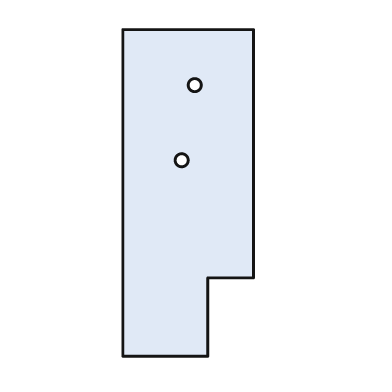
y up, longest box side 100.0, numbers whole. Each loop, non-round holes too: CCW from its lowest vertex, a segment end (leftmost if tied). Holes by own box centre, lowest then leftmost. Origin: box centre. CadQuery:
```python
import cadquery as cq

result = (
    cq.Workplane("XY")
    .moveTo(-20.0, -50.0)
    .lineTo(6.0, -50.0)
    .lineTo(6.0, -26.0)
    .lineTo(20.0, -26.0)
    .lineTo(20.0, 50.0)
    .lineTo(-20.0, 50.0)
    .close()
    .moveTo(-2.0, 10.0)
    .circle(2.0)
    .moveTo(2.0, 33.0)
    .circle(2.0)
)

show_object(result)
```